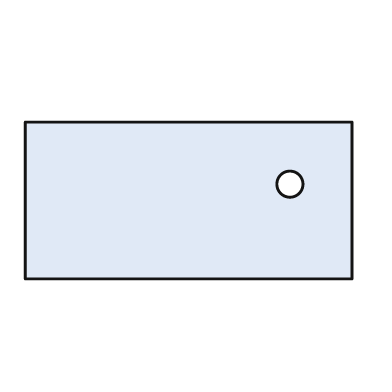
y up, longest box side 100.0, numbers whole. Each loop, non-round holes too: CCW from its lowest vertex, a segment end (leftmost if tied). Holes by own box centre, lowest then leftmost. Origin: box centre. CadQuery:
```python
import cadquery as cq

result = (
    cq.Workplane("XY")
    .moveTo(-50.0, -24.0)
    .lineTo(50.0, -24.0)
    .lineTo(50.0, 24.0)
    .lineTo(-50.0, 24.0)
    .close()
    .moveTo(31.0, 5.0)
    .circle(4.0)
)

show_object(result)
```